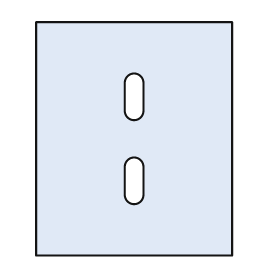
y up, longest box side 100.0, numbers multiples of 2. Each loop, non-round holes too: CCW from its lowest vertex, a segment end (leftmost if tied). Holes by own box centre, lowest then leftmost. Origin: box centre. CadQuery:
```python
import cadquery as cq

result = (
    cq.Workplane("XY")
    .moveTo(-42.0, -50.0)
    .lineTo(42.0, -50.0)
    .lineTo(42.0, 50.0)
    .lineTo(-42.0, 50.0)
    .close()
    .moveTo(-4.0, -24.0)
    .threePointArc((0.0, -28.0), (4.0, -24.0))
    .lineTo(4.0, -12.0)
    .threePointArc((0.0, -8.0), (-4.0, -12.0))
    .close()
    .moveTo(-4.0, 12.0)
    .threePointArc((0.0, 8.0), (4.0, 12.0))
    .lineTo(4.0, 24.0)
    .threePointArc((0.0, 28.0), (-4.0, 24.0))
    .close()
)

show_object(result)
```